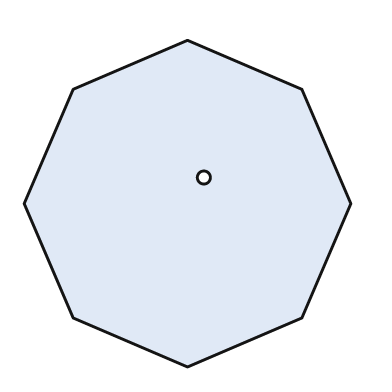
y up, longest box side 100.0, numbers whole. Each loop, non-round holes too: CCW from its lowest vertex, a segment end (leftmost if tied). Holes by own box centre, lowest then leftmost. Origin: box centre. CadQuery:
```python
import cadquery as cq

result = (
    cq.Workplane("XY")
    .moveTo(0.0, -50.0)
    .lineTo(35.0, -35.0)
    .lineTo(50.0, 0.0)
    .lineTo(35.0, 35.0)
    .lineTo(0.0, 50.0)
    .lineTo(-35.0, 35.0)
    .lineTo(-50.0, 0.0)
    .lineTo(-35.0, -35.0)
    .close()
    .moveTo(5.0, 8.0)
    .circle(2.0)
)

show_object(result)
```